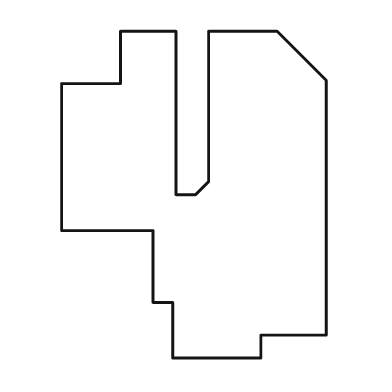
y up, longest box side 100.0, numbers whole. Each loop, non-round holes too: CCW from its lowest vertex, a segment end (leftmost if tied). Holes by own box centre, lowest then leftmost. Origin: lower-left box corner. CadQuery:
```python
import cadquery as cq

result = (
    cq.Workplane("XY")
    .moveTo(34.0, 0.0)
    .lineTo(61.0, 0.0)
    .lineTo(61.0, 7.0)
    .lineTo(81.0, 7.0)
    .lineTo(81.0, 85.0)
    .lineTo(66.0, 100.0)
    .lineTo(45.0, 100.0)
    .lineTo(45.0, 54.0)
    .lineTo(41.0, 50.0)
    .lineTo(35.0, 50.0)
    .lineTo(35.0, 100.0)
    .lineTo(18.0, 100.0)
    .lineTo(18.0, 84.0)
    .lineTo(0.0, 84.0)
    .lineTo(0.0, 39.0)
    .lineTo(28.0, 39.0)
    .lineTo(28.0, 17.0)
    .lineTo(34.0, 17.0)
    .close()
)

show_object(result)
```